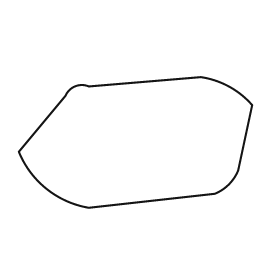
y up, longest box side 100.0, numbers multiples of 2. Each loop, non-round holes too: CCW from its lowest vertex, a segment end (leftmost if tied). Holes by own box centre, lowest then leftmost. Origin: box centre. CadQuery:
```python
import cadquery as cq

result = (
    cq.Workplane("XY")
    .moveTo(-20.0, -28.0)
    .lineTo(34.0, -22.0)
    .threePointArc((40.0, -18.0), (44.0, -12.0))
    .lineTo(50.0, 16.0)
    .threePointArc((40.0, 24.0), (28.0, 28.0))
    .lineTo(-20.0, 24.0)
    .threePointArc((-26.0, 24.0), (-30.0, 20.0))
    .lineTo(-50.0, -4.0)
    .threePointArc((-38.0, -20.0), (-20.0, -28.0))
    .close()
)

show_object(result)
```